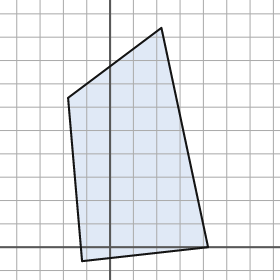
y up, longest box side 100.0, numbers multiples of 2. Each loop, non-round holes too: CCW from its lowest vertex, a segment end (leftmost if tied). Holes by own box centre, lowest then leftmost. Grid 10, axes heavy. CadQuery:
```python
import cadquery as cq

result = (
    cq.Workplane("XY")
    .moveTo(-12.0, -6.0)
    .lineTo(42.0, 0.0)
    .lineTo(22.0, 94.0)
    .lineTo(-18.0, 64.0)
    .close()
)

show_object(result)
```